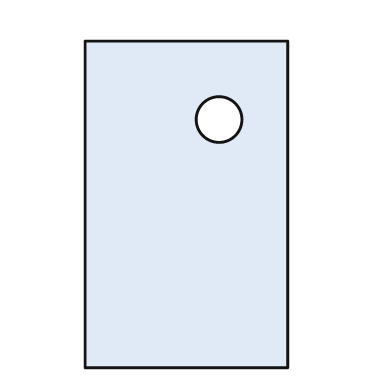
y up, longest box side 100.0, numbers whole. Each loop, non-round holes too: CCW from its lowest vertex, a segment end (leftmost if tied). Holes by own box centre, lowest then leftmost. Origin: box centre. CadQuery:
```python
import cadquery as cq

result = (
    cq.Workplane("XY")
    .moveTo(-31.0, -50.0)
    .lineTo(31.0, -50.0)
    .lineTo(31.0, 50.0)
    .lineTo(-31.0, 50.0)
    .close()
    .moveTo(10.0, 26.0)
    .circle(7.0)
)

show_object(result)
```